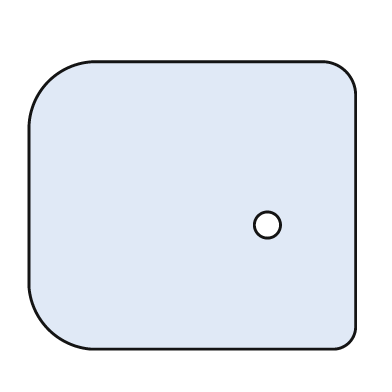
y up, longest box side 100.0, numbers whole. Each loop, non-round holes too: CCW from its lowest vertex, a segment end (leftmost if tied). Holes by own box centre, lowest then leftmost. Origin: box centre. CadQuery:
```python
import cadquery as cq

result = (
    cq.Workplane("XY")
    .moveTo(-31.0, -44.0)
    .lineTo(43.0, -44.0)
    .threePointArc((48.0, -42.0), (50.0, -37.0))
    .lineTo(50.0, 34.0)
    .threePointArc((47.0, 41.0), (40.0, 44.0))
    .lineTo(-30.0, 44.0)
    .threePointArc((-44.0, 38.0), (-50.0, 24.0))
    .lineTo(-50.0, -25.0)
    .threePointArc((-44.0, -38.0), (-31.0, -44.0))
    .close()
    .moveTo(23.0, -6.0)
    .circle(4.0)
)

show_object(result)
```